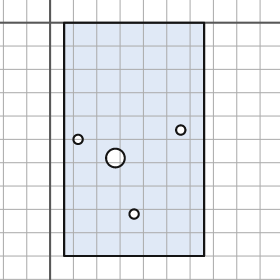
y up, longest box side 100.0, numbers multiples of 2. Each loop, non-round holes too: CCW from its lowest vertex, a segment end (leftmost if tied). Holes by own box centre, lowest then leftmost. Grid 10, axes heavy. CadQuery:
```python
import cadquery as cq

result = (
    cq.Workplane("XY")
    .moveTo(6.0, -100.0)
    .lineTo(66.0, -100.0)
    .lineTo(66.0, 0.0)
    .lineTo(6.0, 0.0)
    .close()
    .moveTo(36.0, -82.0)
    .circle(2.0)
    .moveTo(28.0, -58.0)
    .circle(4.0)
    .moveTo(12.0, -50.0)
    .circle(2.0)
    .moveTo(56.0, -46.0)
    .circle(2.0)
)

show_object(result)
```